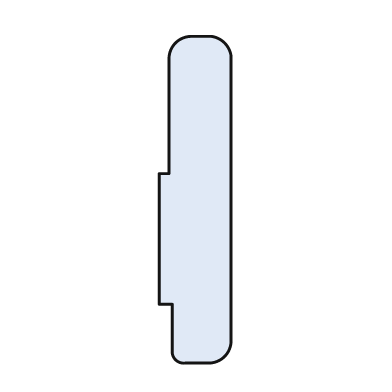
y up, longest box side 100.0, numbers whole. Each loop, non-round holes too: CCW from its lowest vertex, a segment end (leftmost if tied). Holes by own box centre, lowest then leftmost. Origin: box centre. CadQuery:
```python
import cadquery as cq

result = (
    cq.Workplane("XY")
    .moveTo(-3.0, -50.0)
    .lineTo(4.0, -50.0)
    .threePointArc((9.0, -48.0), (11.0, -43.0))
    .lineTo(11.0, 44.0)
    .threePointArc((9.0, 48.0), (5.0, 50.0))
    .lineTo(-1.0, 50.0)
    .threePointArc((-6.0, 48.0), (-8.0, 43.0))
    .lineTo(-8.0, 8.0)
    .lineTo(-11.0, 8.0)
    .lineTo(-11.0, -32.0)
    .lineTo(-7.0, -32.0)
    .lineTo(-7.0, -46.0)
    .threePointArc((-6.0, -49.0), (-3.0, -50.0))
    .close()
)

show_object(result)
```